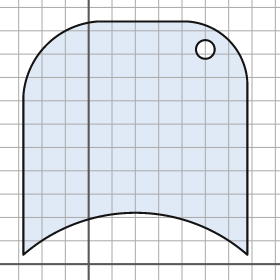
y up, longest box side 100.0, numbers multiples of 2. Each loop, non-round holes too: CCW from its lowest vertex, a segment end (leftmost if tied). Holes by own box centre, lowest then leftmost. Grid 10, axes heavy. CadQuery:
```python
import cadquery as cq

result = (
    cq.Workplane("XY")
    .moveTo(-28.0, 4.0)
    .threePointArc((20.0, 22.0), (68.0, 4.0))
    .lineTo(68.0, 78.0)
    .threePointArc((60.0, 96.0), (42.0, 104.0))
    .lineTo(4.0, 104.0)
    .threePointArc((-18.0, 94.0), (-28.0, 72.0))
    .close()
    .moveTo(50.0, 92.0)
    .circle(4.0)
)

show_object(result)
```